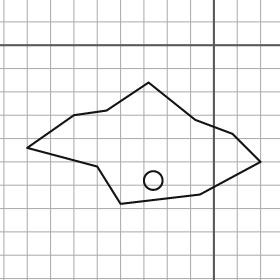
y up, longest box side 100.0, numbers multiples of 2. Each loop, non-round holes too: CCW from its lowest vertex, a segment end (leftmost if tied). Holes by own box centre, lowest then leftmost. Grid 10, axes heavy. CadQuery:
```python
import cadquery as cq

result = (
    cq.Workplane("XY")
    .moveTo(-40.0, -68.0)
    .lineTo(-6.0, -64.0)
    .lineTo(20.0, -50.0)
    .lineTo(8.0, -38.0)
    .lineTo(-8.0, -32.0)
    .lineTo(-28.0, -16.0)
    .lineTo(-46.0, -28.0)
    .lineTo(-60.0, -30.0)
    .lineTo(-80.0, -44.0)
    .lineTo(-50.0, -52.0)
    .close()
    .moveTo(-26.0, -58.0)
    .circle(4.0)
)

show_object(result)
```